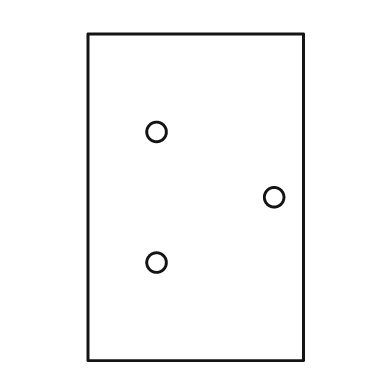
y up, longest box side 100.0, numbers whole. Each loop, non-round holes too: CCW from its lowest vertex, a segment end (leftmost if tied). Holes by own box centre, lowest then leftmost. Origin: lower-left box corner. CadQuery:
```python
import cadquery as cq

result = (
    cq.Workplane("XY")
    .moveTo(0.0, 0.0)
    .lineTo(66.0, 0.0)
    .lineTo(66.0, 100.0)
    .lineTo(0.0, 100.0)
    .close()
    .moveTo(21.0, 30.0)
    .circle(3.0)
    .moveTo(57.0, 50.0)
    .circle(3.0)
    .moveTo(21.0, 70.0)
    .circle(3.0)
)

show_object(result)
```